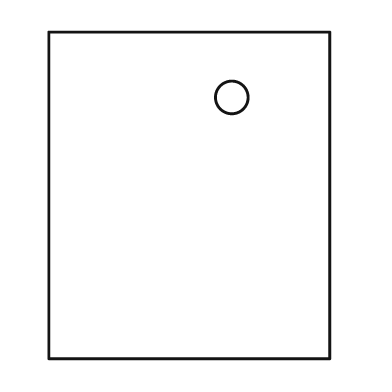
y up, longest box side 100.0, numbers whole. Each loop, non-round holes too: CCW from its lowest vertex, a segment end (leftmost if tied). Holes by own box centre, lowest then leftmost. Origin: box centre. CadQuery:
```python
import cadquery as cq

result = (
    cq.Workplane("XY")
    .moveTo(-43.0, -50.0)
    .lineTo(43.0, -50.0)
    .lineTo(43.0, 50.0)
    .lineTo(-43.0, 50.0)
    .close()
    .moveTo(13.0, 30.0)
    .circle(5.0)
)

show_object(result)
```